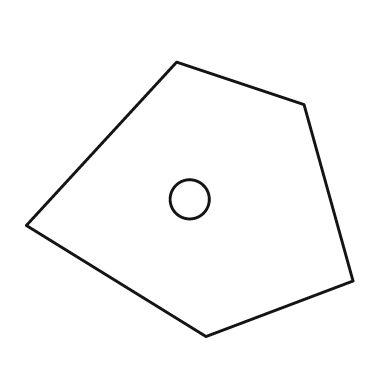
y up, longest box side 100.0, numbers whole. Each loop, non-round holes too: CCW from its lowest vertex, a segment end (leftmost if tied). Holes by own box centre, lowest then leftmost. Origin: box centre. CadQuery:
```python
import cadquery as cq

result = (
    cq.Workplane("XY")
    .moveTo(5.0, -42.0)
    .lineTo(50.0, -25.0)
    .lineTo(35.0, 29.0)
    .lineTo(-4.0, 42.0)
    .lineTo(-50.0, -8.0)
    .close()
    .moveTo(0.0, 0.0)
    .circle(6.0)
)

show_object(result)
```